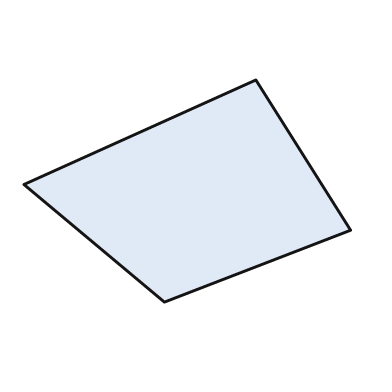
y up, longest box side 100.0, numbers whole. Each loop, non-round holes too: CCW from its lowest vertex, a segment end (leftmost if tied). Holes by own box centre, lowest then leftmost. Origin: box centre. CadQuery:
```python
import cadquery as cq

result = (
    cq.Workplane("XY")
    .moveTo(-7.0, -34.0)
    .lineTo(50.0, -12.0)
    .lineTo(21.0, 34.0)
    .lineTo(-50.0, 2.0)
    .close()
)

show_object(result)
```